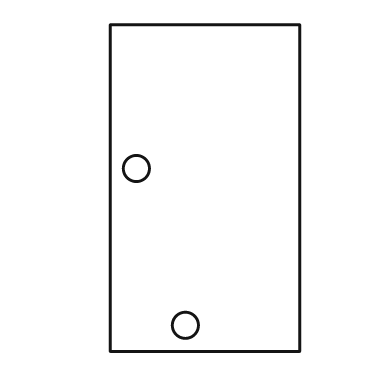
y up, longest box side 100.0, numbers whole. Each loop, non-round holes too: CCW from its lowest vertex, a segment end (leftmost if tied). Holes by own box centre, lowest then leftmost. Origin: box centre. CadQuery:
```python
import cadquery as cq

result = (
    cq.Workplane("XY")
    .moveTo(-29.0, -50.0)
    .lineTo(29.0, -50.0)
    .lineTo(29.0, 50.0)
    .lineTo(-29.0, 50.0)
    .close()
    .moveTo(-6.0, -42.0)
    .circle(4.0)
    .moveTo(-21.0, 6.0)
    .circle(4.0)
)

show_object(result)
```